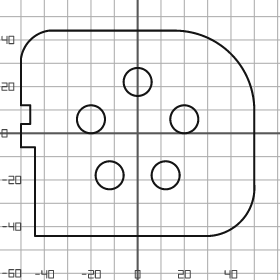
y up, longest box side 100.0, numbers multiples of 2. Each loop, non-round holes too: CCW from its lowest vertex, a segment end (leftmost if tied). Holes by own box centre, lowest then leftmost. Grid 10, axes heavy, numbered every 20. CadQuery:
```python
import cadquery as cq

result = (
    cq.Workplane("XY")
    .moveTo(-44.0, -44.0)
    .lineTo(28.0, -44.0)
    .threePointArc((44.0, -38.0), (50.0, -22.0))
    .lineTo(50.0, 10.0)
    .threePointArc((40.0, 34.0), (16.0, 44.0))
    .lineTo(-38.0, 44.0)
    .threePointArc((-46.0, 40.0), (-50.0, 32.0))
    .lineTo(-50.0, 12.0)
    .lineTo(-46.0, 12.0)
    .lineTo(-46.0, 4.0)
    .lineTo(-50.0, 4.0)
    .lineTo(-50.0, -6.0)
    .lineTo(-44.0, -6.0)
    .close()
    .moveTo(-12.0, -18.0)
    .circle(6.0)
    .moveTo(12.0, -18.0)
    .circle(6.0)
    .moveTo(-20.0, 6.0)
    .circle(6.0)
    .moveTo(20.0, 6.0)
    .circle(6.0)
    .moveTo(0.0, 22.0)
    .circle(6.0)
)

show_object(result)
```